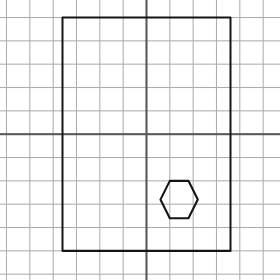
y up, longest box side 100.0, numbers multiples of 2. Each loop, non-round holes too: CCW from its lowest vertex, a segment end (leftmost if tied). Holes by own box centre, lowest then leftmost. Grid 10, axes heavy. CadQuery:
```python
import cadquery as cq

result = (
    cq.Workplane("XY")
    .moveTo(-36.0, -50.0)
    .lineTo(36.0, -50.0)
    .lineTo(36.0, 50.0)
    .lineTo(-36.0, 50.0)
    .close()
    .moveTo(10.0, -36.0)
    .lineTo(18.0, -36.0)
    .lineTo(22.0, -28.0)
    .lineTo(18.0, -20.0)
    .lineTo(10.0, -20.0)
    .lineTo(6.0, -28.0)
    .close()
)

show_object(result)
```